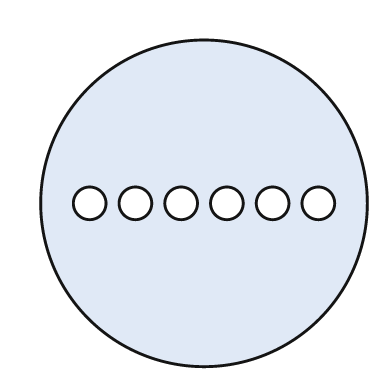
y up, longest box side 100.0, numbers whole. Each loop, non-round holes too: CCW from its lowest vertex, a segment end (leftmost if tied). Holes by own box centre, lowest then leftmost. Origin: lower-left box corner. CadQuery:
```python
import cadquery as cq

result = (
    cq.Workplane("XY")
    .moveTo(50.0, 50.0)
    .circle(50.0)
    .moveTo(15.0, 50.0)
    .circle(5.0)
    .moveTo(29.0, 50.0)
    .circle(5.0)
    .moveTo(43.0, 50.0)
    .circle(5.0)
    .moveTo(57.0, 50.0)
    .circle(5.0)
    .moveTo(71.0, 50.0)
    .circle(5.0)
    .moveTo(85.0, 50.0)
    .circle(5.0)
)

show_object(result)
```